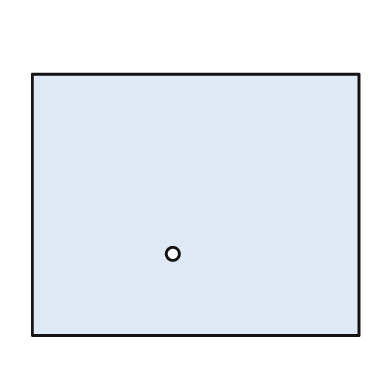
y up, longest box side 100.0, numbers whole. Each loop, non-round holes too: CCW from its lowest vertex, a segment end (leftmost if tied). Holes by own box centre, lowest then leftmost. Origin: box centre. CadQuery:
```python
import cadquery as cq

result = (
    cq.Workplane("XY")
    .moveTo(-50.0, -40.0)
    .lineTo(50.0, -40.0)
    .lineTo(50.0, 40.0)
    .lineTo(-50.0, 40.0)
    .close()
    .moveTo(-7.0, -15.0)
    .circle(2.0)
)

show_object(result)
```